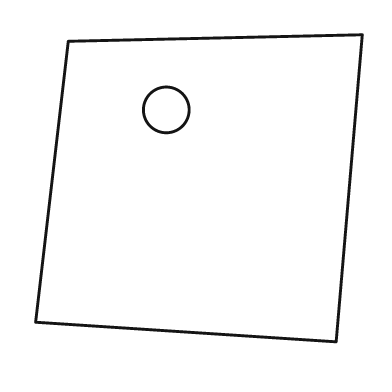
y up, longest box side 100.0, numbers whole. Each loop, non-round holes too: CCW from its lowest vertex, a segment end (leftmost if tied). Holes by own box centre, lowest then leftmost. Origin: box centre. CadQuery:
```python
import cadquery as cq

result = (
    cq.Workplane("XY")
    .moveTo(42.0, -47.0)
    .lineTo(50.0, 47.0)
    .lineTo(-40.0, 45.0)
    .lineTo(-50.0, -41.0)
    .close()
    .moveTo(-10.0, 24.0)
    .circle(7.0)
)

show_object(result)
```